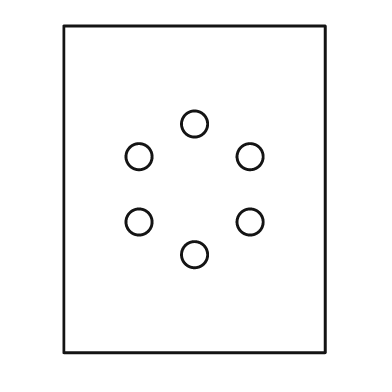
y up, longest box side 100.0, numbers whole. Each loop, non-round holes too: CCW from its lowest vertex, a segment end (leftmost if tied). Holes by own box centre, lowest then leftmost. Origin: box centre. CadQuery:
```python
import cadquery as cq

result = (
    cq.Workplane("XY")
    .moveTo(-40.0, -50.0)
    .lineTo(40.0, -50.0)
    .lineTo(40.0, 50.0)
    .lineTo(-40.0, 50.0)
    .close()
    .moveTo(0.0, -20.0)
    .circle(4.0)
    .moveTo(-17.0, -10.0)
    .circle(4.0)
    .moveTo(17.0, -10.0)
    .circle(4.0)
    .moveTo(-17.0, 10.0)
    .circle(4.0)
    .moveTo(17.0, 10.0)
    .circle(4.0)
    .moveTo(0.0, 20.0)
    .circle(4.0)
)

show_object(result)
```